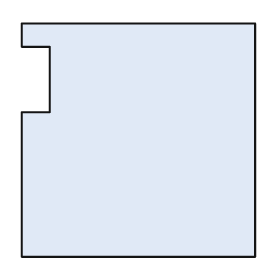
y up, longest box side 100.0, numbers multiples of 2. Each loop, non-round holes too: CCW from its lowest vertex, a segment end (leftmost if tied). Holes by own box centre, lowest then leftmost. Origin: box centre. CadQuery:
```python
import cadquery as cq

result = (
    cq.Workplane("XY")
    .moveTo(-50.0, -50.0)
    .lineTo(50.0, -50.0)
    .lineTo(50.0, 50.0)
    .lineTo(-50.0, 50.0)
    .lineTo(-50.0, 40.0)
    .lineTo(-38.0, 40.0)
    .lineTo(-38.0, 12.0)
    .lineTo(-50.0, 12.0)
    .close()
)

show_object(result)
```